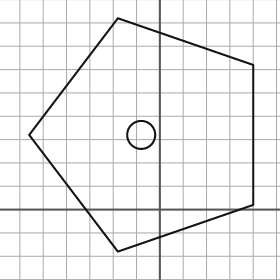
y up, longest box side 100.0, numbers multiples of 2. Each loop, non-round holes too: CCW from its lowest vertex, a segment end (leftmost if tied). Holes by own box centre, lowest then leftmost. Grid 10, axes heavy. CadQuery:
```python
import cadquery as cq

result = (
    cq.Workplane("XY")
    .moveTo(-18.0, -18.0)
    .lineTo(40.0, 2.0)
    .lineTo(40.0, 62.0)
    .lineTo(-18.0, 82.0)
    .lineTo(-56.0, 32.0)
    .close()
    .moveTo(-8.0, 32.0)
    .circle(6.0)
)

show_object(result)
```